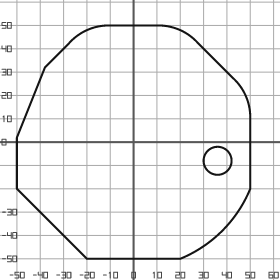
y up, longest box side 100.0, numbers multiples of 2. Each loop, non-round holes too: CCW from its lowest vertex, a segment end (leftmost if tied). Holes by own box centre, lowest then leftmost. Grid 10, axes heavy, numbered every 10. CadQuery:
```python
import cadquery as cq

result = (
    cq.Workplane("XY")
    .moveTo(-20.0, -50.0)
    .lineTo(20.0, -50.0)
    .threePointArc((38.0, -38.0), (50.0, -20.0))
    .lineTo(50.0, 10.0)
    .threePointArc((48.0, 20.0), (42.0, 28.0))
    .lineTo(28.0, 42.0)
    .threePointArc((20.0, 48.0), (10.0, 50.0))
    .lineTo(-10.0, 50.0)
    .threePointArc((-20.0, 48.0), (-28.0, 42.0))
    .lineTo(-38.0, 32.0)
    .lineTo(-50.0, 2.0)
    .lineTo(-50.0, -20.0)
    .close()
    .moveTo(36.0, -8.0)
    .circle(6.0)
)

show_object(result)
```